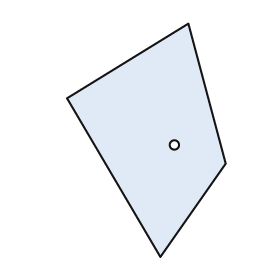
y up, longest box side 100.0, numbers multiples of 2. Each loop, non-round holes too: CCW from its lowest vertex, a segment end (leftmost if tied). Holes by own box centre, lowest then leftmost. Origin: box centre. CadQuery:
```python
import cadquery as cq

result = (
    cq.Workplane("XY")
    .moveTo(6.0, -50.0)
    .lineTo(34.0, -10.0)
    .lineTo(18.0, 50.0)
    .lineTo(-34.0, 18.0)
    .close()
    .moveTo(12.0, -2.0)
    .circle(2.0)
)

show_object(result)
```